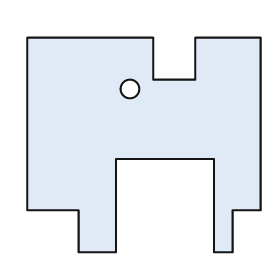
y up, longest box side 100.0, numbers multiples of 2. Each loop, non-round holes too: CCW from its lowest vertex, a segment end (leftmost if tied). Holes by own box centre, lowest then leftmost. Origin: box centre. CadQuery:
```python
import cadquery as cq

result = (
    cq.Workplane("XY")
    .moveTo(-28.0, -46.0)
    .lineTo(-12.0, -46.0)
    .lineTo(-12.0, -6.0)
    .lineTo(30.0, -6.0)
    .lineTo(30.0, -46.0)
    .lineTo(38.0, -46.0)
    .lineTo(38.0, -28.0)
    .lineTo(50.0, -28.0)
    .lineTo(50.0, 46.0)
    .lineTo(22.0, 46.0)
    .lineTo(22.0, 28.0)
    .lineTo(4.0, 28.0)
    .lineTo(4.0, 46.0)
    .lineTo(-50.0, 46.0)
    .lineTo(-50.0, -28.0)
    .lineTo(-28.0, -28.0)
    .close()
    .moveTo(-6.0, 24.0)
    .circle(4.0)
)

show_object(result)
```